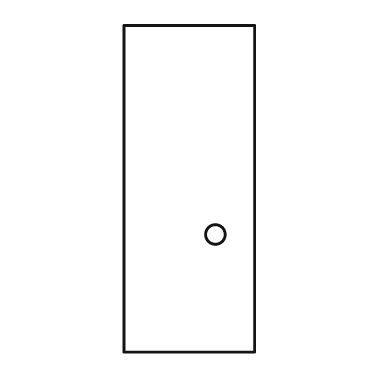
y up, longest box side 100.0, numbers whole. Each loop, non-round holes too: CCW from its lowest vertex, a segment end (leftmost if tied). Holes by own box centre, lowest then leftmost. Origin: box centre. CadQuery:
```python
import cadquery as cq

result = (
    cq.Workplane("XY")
    .moveTo(-20.0, -50.0)
    .lineTo(20.0, -50.0)
    .lineTo(20.0, 50.0)
    .lineTo(-20.0, 50.0)
    .close()
    .moveTo(8.0, -14.0)
    .circle(3.0)
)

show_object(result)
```